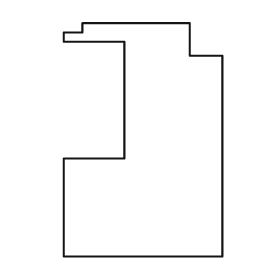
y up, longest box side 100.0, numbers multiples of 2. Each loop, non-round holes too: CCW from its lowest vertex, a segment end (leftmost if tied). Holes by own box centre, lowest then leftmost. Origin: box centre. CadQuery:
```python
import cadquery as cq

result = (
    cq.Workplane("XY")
    .moveTo(-34.0, -50.0)
    .lineTo(34.0, -50.0)
    .lineTo(34.0, 36.0)
    .lineTo(20.0, 36.0)
    .lineTo(20.0, 50.0)
    .lineTo(-26.0, 50.0)
    .lineTo(-26.0, 46.0)
    .lineTo(-34.0, 46.0)
    .lineTo(-34.0, 42.0)
    .lineTo(-8.0, 42.0)
    .lineTo(-8.0, -8.0)
    .lineTo(-34.0, -8.0)
    .close()
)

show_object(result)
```